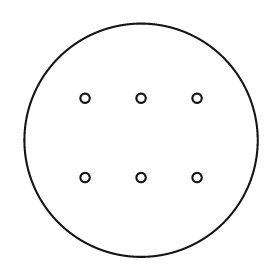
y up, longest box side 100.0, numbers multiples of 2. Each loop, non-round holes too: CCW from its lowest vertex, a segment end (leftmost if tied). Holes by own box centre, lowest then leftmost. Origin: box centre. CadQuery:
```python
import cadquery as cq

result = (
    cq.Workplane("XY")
    .moveTo(0.0, 0.0)
    .circle(50.0)
    .moveTo(-24.0, -16.0)
    .circle(2.0)
    .moveTo(0.0, -16.0)
    .circle(2.0)
    .moveTo(24.0, -16.0)
    .circle(2.0)
    .moveTo(-24.0, 18.0)
    .circle(2.0)
    .moveTo(0.0, 18.0)
    .circle(2.0)
    .moveTo(24.0, 18.0)
    .circle(2.0)
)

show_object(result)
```